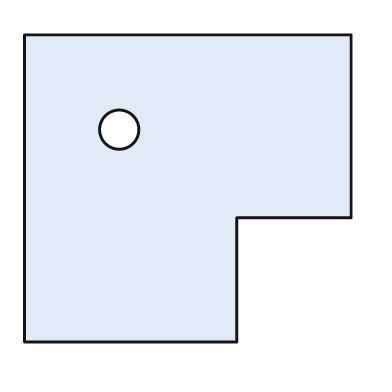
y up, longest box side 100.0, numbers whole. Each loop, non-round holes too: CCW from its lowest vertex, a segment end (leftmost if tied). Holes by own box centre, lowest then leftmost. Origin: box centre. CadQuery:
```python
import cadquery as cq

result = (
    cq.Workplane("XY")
    .moveTo(-50.0, -47.0)
    .lineTo(15.0, -47.0)
    .lineTo(15.0, -9.0)
    .lineTo(50.0, -9.0)
    .lineTo(50.0, 47.0)
    .lineTo(-50.0, 47.0)
    .close()
    .moveTo(-21.0, 18.0)
    .circle(6.0)
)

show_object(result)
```